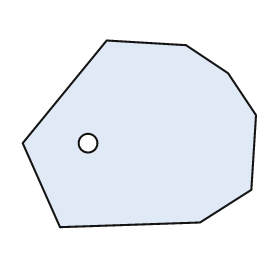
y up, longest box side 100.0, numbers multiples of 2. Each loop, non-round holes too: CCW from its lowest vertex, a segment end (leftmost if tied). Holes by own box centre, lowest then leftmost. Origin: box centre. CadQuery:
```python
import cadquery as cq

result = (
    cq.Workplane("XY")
    .moveTo(-34.0, -40.0)
    .lineTo(26.0, -38.0)
    .lineTo(48.0, -24.0)
    .lineTo(50.0, 8.0)
    .lineTo(38.0, 26.0)
    .lineTo(20.0, 38.0)
    .lineTo(-14.0, 40.0)
    .lineTo(-50.0, -4.0)
    .close()
    .moveTo(-22.0, -4.0)
    .circle(4.0)
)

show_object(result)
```